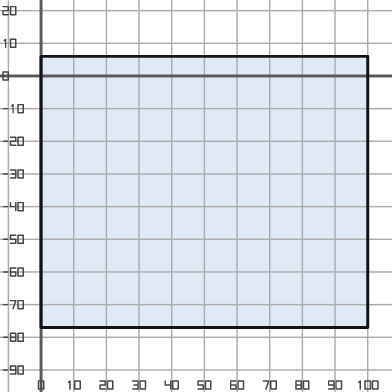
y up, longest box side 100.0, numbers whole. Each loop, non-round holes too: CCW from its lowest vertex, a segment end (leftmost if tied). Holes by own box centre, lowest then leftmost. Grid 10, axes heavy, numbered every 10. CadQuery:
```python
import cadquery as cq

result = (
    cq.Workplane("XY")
    .moveTo(0.0, -77.0)
    .lineTo(100.0, -77.0)
    .lineTo(100.0, 6.0)
    .lineTo(0.0, 6.0)
    .close()
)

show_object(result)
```